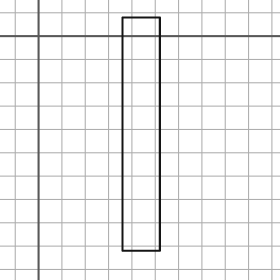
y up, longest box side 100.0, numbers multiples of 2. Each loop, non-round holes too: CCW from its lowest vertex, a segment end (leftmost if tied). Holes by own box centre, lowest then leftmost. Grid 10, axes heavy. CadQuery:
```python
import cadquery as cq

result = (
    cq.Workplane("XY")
    .moveTo(36.0, -92.0)
    .lineTo(52.0, -92.0)
    .lineTo(52.0, 8.0)
    .lineTo(36.0, 8.0)
    .close()
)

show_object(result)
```